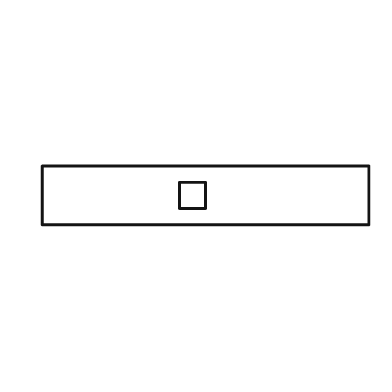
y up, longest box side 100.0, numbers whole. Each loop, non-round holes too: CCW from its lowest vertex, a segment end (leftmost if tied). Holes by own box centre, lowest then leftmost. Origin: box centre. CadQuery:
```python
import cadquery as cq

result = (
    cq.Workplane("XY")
    .moveTo(-50.0, -9.0)
    .lineTo(50.0, -9.0)
    .lineTo(50.0, 9.0)
    .lineTo(-50.0, 9.0)
    .close()
    .moveTo(-8.0, -4.0)
    .lineTo(0.0, -4.0)
    .lineTo(0.0, 4.0)
    .lineTo(-8.0, 4.0)
    .close()
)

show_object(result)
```